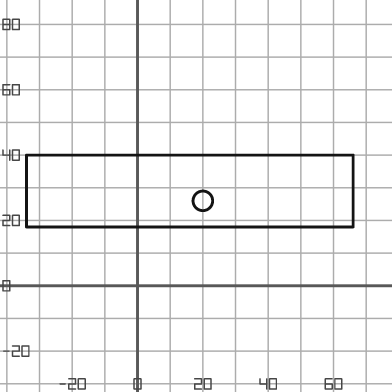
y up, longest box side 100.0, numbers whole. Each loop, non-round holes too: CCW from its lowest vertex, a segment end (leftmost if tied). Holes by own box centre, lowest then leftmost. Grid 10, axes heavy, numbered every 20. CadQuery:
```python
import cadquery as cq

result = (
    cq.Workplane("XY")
    .moveTo(-34.0, 18.0)
    .lineTo(66.0, 18.0)
    .lineTo(66.0, 40.0)
    .lineTo(-34.0, 40.0)
    .close()
    .moveTo(20.0, 26.0)
    .circle(3.0)
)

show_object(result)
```